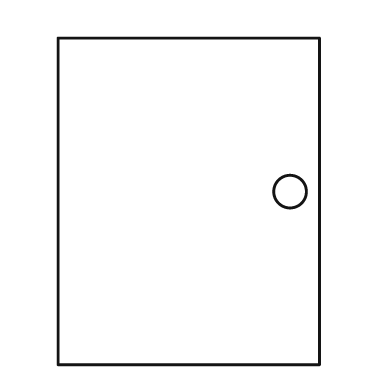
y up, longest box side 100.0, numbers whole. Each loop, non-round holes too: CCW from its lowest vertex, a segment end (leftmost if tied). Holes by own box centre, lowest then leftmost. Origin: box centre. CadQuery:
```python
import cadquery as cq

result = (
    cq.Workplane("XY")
    .moveTo(-40.0, -50.0)
    .lineTo(40.0, -50.0)
    .lineTo(40.0, 50.0)
    .lineTo(-40.0, 50.0)
    .close()
    .moveTo(31.0, 3.0)
    .circle(5.0)
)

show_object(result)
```